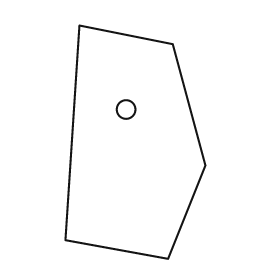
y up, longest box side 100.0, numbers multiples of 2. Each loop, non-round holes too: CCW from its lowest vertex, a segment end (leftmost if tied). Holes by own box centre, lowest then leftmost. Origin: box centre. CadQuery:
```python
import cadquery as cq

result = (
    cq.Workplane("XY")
    .moveTo(14.0, -50.0)
    .lineTo(30.0, -10.0)
    .lineTo(16.0, 42.0)
    .lineTo(-24.0, 50.0)
    .lineTo(-30.0, -42.0)
    .close()
    .moveTo(-4.0, 14.0)
    .circle(4.0)
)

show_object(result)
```